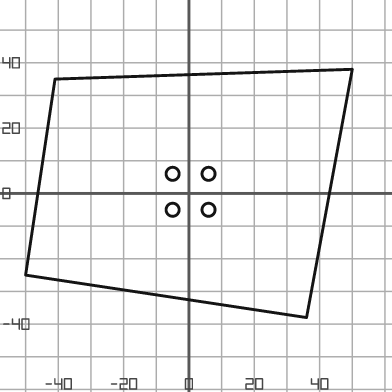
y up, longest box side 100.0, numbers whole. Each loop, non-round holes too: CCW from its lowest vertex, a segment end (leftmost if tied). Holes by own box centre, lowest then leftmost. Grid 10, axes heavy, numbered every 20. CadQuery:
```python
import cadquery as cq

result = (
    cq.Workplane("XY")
    .moveTo(36.0, -38.0)
    .lineTo(50.0, 38.0)
    .lineTo(-41.0, 35.0)
    .lineTo(-50.0, -25.0)
    .close()
    .moveTo(-5.0, -5.0)
    .circle(2.0)
    .moveTo(6.0, -5.0)
    .circle(2.0)
    .moveTo(-5.0, 6.0)
    .circle(2.0)
    .moveTo(6.0, 6.0)
    .circle(2.0)
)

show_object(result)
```